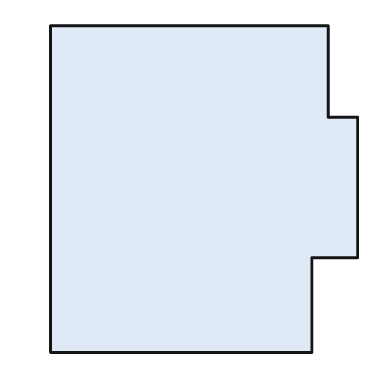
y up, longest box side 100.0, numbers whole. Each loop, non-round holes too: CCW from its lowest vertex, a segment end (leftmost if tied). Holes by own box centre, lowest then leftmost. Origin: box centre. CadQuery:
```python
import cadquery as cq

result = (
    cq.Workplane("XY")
    .moveTo(-47.0, -50.0)
    .lineTo(33.0, -50.0)
    .lineTo(33.0, -21.0)
    .lineTo(47.0, -21.0)
    .lineTo(47.0, 22.0)
    .lineTo(38.0, 22.0)
    .lineTo(38.0, 50.0)
    .lineTo(-47.0, 50.0)
    .close()
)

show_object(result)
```